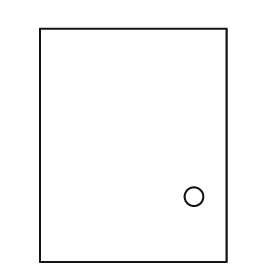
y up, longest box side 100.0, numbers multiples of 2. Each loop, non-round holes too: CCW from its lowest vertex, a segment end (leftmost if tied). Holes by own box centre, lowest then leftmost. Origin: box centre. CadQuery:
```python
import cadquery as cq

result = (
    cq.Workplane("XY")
    .moveTo(-40.0, -50.0)
    .lineTo(40.0, -50.0)
    .lineTo(40.0, 50.0)
    .lineTo(-40.0, 50.0)
    .close()
    .moveTo(26.0, -22.0)
    .circle(4.0)
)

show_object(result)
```